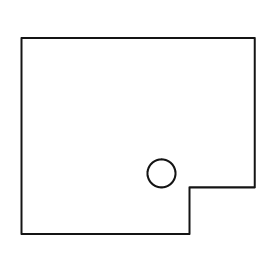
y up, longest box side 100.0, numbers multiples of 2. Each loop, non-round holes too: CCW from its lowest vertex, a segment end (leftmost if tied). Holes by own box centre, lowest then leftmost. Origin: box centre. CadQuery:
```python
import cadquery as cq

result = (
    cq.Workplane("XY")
    .moveTo(-50.0, -42.0)
    .lineTo(22.0, -42.0)
    .lineTo(22.0, -22.0)
    .lineTo(50.0, -22.0)
    .lineTo(50.0, 42.0)
    .lineTo(-50.0, 42.0)
    .close()
    .moveTo(10.0, -16.0)
    .circle(6.0)
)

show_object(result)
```